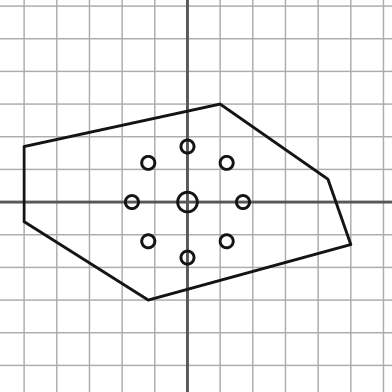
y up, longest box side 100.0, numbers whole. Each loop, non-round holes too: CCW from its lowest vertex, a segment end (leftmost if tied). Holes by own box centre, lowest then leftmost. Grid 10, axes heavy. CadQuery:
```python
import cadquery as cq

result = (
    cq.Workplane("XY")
    .moveTo(-12.0, -30.0)
    .lineTo(50.0, -13.0)
    .lineTo(43.0, 7.0)
    .lineTo(10.0, 30.0)
    .lineTo(-50.0, 17.0)
    .lineTo(-50.0, -6.0)
    .close()
    .moveTo(0.0, -17.0)
    .circle(2.0)
    .moveTo(-12.0, -12.0)
    .circle(2.0)
    .moveTo(12.0, -12.0)
    .circle(2.0)
    .moveTo(-17.0, 0.0)
    .circle(2.0)
    .moveTo(0.0, 0.0)
    .circle(3.0)
    .moveTo(17.0, 0.0)
    .circle(2.0)
    .moveTo(-12.0, 12.0)
    .circle(2.0)
    .moveTo(12.0, 12.0)
    .circle(2.0)
    .moveTo(0.0, 17.0)
    .circle(2.0)
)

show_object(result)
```